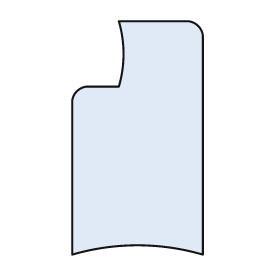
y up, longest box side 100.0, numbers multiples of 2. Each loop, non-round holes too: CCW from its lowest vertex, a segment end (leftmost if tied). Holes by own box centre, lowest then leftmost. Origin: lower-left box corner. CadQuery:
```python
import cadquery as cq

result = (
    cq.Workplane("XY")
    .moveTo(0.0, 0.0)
    .threePointArc((28.0, 4.0), (56.0, 0.0))
    .lineTo(56.0, 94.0)
    .threePointArc((54.0, 98.0), (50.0, 100.0))
    .lineTo(20.0, 100.0)
    .threePointArc((22.0, 86.0), (20.0, 72.0))
    .lineTo(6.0, 72.0)
    .threePointArc((2.0, 70.0), (0.0, 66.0))
    .close()
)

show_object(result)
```